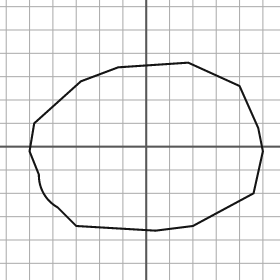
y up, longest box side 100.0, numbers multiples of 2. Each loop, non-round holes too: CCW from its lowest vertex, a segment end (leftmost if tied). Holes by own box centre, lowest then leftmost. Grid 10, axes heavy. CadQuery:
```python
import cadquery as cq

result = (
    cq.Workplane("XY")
    .moveTo(4.0, -36.0)
    .lineTo(20.0, -34.0)
    .lineTo(46.0, -20.0)
    .lineTo(50.0, -2.0)
    .lineTo(48.0, 8.0)
    .lineTo(40.0, 26.0)
    .lineTo(18.0, 36.0)
    .lineTo(-12.0, 34.0)
    .lineTo(-28.0, 28.0)
    .lineTo(-48.0, 10.0)
    .lineTo(-50.0, -2.0)
    .lineTo(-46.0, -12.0)
    .threePointArc((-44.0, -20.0), (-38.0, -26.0))
    .lineTo(-30.0, -34.0)
    .close()
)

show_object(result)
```